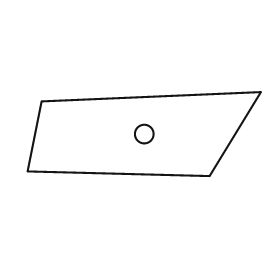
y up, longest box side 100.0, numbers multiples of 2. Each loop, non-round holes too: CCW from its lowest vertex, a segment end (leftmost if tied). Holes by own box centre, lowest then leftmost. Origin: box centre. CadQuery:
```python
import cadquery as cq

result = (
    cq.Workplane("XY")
    .moveTo(28.0, -18.0)
    .lineTo(50.0, 18.0)
    .lineTo(-44.0, 14.0)
    .lineTo(-50.0, -16.0)
    .close()
    .moveTo(0.0, 0.0)
    .circle(4.0)
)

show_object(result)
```